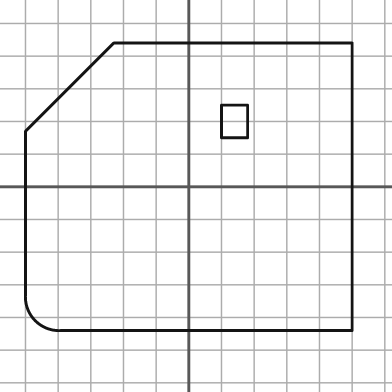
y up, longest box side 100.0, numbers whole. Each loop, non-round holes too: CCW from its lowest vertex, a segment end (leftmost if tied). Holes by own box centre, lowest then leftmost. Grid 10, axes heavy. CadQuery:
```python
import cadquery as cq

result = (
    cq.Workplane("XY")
    .moveTo(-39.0, -44.0)
    .lineTo(50.0, -44.0)
    .lineTo(50.0, 44.0)
    .lineTo(-23.0, 44.0)
    .lineTo(-50.0, 17.0)
    .lineTo(-50.0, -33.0)
    .threePointArc((-47.0, -41.0), (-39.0, -44.0))
    .close()
    .moveTo(10.0, 15.0)
    .lineTo(18.0, 15.0)
    .lineTo(18.0, 25.0)
    .lineTo(10.0, 25.0)
    .close()
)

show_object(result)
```